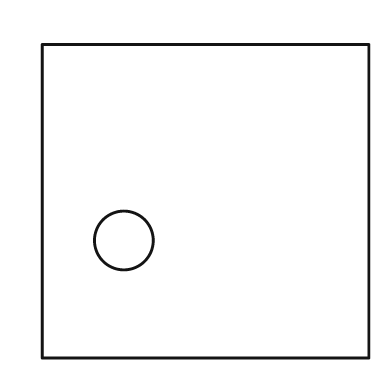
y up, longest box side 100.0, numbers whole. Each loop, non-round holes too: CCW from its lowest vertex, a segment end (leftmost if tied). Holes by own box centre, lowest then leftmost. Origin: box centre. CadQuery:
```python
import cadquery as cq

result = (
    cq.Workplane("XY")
    .moveTo(-50.0, -48.0)
    .lineTo(50.0, -48.0)
    .lineTo(50.0, 48.0)
    .lineTo(-50.0, 48.0)
    .close()
    .moveTo(-25.0, -12.0)
    .circle(9.0)
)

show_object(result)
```